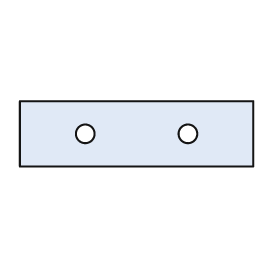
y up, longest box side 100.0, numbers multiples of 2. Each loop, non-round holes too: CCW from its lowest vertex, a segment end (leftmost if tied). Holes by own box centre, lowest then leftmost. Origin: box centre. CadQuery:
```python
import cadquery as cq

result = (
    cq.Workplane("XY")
    .moveTo(-50.0, -14.0)
    .lineTo(50.0, -14.0)
    .lineTo(50.0, 14.0)
    .lineTo(-50.0, 14.0)
    .close()
    .moveTo(-22.0, 0.0)
    .circle(4.0)
    .moveTo(22.0, 0.0)
    .circle(4.0)
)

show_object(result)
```